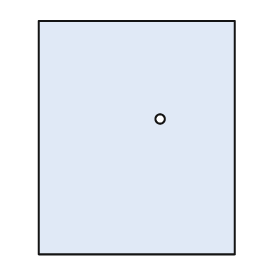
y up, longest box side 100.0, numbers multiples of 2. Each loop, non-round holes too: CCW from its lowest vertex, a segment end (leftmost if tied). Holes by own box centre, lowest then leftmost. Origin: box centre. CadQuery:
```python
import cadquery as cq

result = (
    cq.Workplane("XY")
    .moveTo(-42.0, -50.0)
    .lineTo(42.0, -50.0)
    .lineTo(42.0, 50.0)
    .lineTo(-42.0, 50.0)
    .close()
    .moveTo(10.0, 8.0)
    .circle(2.0)
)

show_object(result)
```